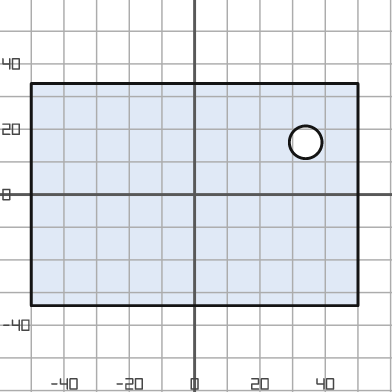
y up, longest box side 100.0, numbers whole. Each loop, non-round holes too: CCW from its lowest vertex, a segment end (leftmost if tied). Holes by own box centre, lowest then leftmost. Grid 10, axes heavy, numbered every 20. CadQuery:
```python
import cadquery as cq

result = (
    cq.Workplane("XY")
    .moveTo(-50.0, -34.0)
    .lineTo(50.0, -34.0)
    .lineTo(50.0, 34.0)
    .lineTo(-50.0, 34.0)
    .close()
    .moveTo(34.0, 16.0)
    .circle(5.0)
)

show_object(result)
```